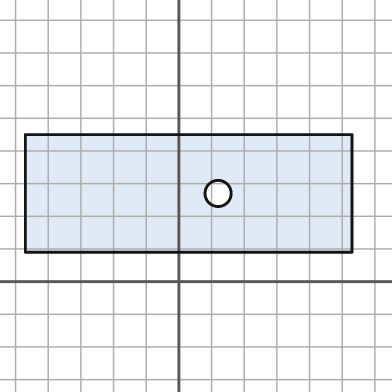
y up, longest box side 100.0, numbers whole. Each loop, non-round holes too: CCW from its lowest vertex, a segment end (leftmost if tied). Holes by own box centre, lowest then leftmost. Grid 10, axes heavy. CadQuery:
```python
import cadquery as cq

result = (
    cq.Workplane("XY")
    .moveTo(-47.0, 9.0)
    .lineTo(53.0, 9.0)
    .lineTo(53.0, 45.0)
    .lineTo(-47.0, 45.0)
    .close()
    .moveTo(12.0, 27.0)
    .circle(4.0)
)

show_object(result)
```